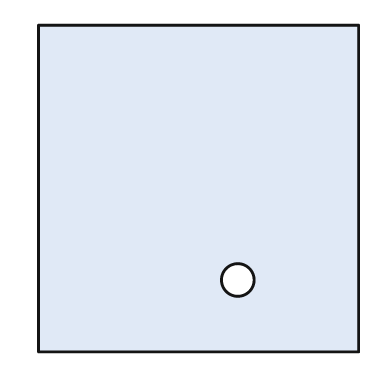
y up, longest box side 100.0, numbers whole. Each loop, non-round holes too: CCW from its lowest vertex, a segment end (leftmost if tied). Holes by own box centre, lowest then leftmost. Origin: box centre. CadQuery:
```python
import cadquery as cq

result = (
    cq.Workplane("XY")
    .moveTo(-49.0, -50.0)
    .lineTo(49.0, -50.0)
    .lineTo(49.0, 50.0)
    .lineTo(-49.0, 50.0)
    .close()
    .moveTo(12.0, -28.0)
    .circle(5.0)
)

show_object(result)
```